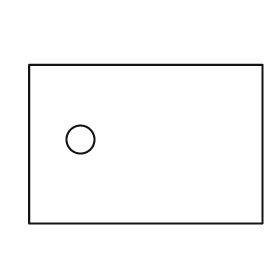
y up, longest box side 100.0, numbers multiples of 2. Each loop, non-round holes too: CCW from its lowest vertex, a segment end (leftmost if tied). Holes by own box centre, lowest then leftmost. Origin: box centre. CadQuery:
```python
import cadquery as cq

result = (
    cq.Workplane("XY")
    .moveTo(-50.0, -34.0)
    .lineTo(50.0, -34.0)
    .lineTo(50.0, 34.0)
    .lineTo(-50.0, 34.0)
    .close()
    .moveTo(-28.0, 2.0)
    .circle(6.0)
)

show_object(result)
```